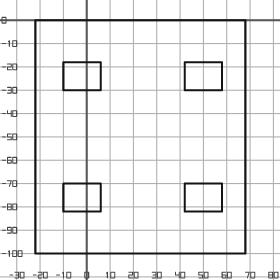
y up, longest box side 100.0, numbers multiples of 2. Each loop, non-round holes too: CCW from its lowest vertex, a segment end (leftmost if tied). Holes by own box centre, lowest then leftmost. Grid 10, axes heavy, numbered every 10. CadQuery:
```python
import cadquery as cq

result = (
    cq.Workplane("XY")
    .moveTo(-22.0, -100.0)
    .lineTo(68.0, -100.0)
    .lineTo(68.0, 0.0)
    .lineTo(-22.0, 0.0)
    .close()
    .moveTo(-10.0, -82.0)
    .lineTo(6.0, -82.0)
    .lineTo(6.0, -70.0)
    .lineTo(-10.0, -70.0)
    .close()
    .moveTo(42.0, -82.0)
    .lineTo(58.0, -82.0)
    .lineTo(58.0, -70.0)
    .lineTo(42.0, -70.0)
    .close()
    .moveTo(-10.0, -30.0)
    .lineTo(6.0, -30.0)
    .lineTo(6.0, -18.0)
    .lineTo(-10.0, -18.0)
    .close()
    .moveTo(42.0, -30.0)
    .lineTo(58.0, -30.0)
    .lineTo(58.0, -18.0)
    .lineTo(42.0, -18.0)
    .close()
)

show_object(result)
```